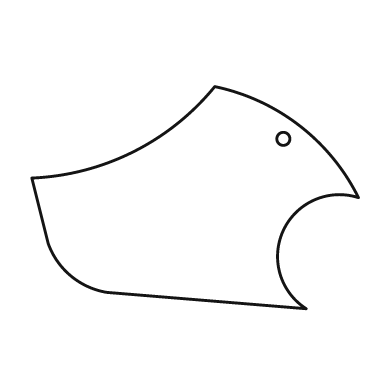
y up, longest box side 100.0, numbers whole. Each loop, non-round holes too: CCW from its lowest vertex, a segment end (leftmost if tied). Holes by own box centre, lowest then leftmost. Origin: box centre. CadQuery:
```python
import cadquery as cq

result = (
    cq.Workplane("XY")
    .moveTo(34.0, -34.0)
    .threePointArc((27.0, -10.0), (50.0, 0.0))
    .threePointArc((32.0, 22.0), (6.0, 34.0))
    .threePointArc((-19.0, 14.0), (-50.0, 6.0))
    .lineTo(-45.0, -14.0)
    .threePointArc((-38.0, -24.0), (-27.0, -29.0))
    .close()
    .moveTo(27.0, 18.0)
    .circle(2.0)
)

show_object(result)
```